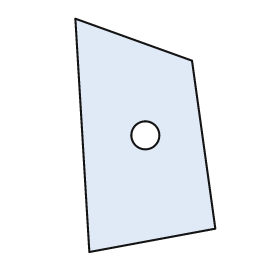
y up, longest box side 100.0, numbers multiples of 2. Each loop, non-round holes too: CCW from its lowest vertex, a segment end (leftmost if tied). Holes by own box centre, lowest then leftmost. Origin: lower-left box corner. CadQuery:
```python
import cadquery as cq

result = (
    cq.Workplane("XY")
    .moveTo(6.0, 0.0)
    .lineTo(60.0, 10.0)
    .lineTo(50.0, 82.0)
    .lineTo(0.0, 100.0)
    .close()
    .moveTo(30.0, 50.0)
    .circle(6.0)
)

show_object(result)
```